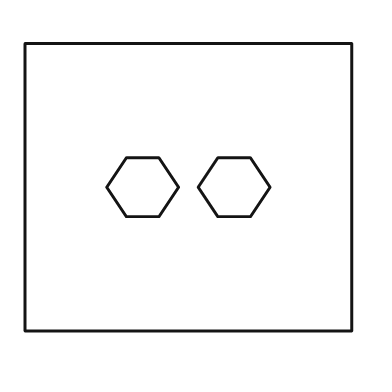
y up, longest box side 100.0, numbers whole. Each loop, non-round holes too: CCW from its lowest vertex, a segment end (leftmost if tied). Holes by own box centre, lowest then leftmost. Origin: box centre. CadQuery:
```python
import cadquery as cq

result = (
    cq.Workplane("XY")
    .moveTo(-50.0, -44.0)
    .lineTo(50.0, -44.0)
    .lineTo(50.0, 44.0)
    .lineTo(-50.0, 44.0)
    .close()
    .moveTo(-19.0, -9.0)
    .lineTo(-9.0, -9.0)
    .lineTo(-3.0, 0.0)
    .lineTo(-9.0, 9.0)
    .lineTo(-19.0, 9.0)
    .lineTo(-25.0, 0.0)
    .close()
    .moveTo(9.0, -9.0)
    .lineTo(19.0, -9.0)
    .lineTo(25.0, 0.0)
    .lineTo(19.0, 9.0)
    .lineTo(9.0, 9.0)
    .lineTo(3.0, 0.0)
    .close()
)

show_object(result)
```